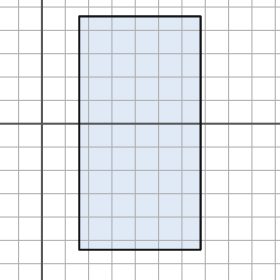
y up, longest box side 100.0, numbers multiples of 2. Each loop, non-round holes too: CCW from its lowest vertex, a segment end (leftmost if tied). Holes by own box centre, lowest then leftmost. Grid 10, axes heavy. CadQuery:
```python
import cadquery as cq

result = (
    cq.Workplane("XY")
    .moveTo(16.0, -54.0)
    .lineTo(68.0, -54.0)
    .lineTo(68.0, 46.0)
    .lineTo(16.0, 46.0)
    .close()
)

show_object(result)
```